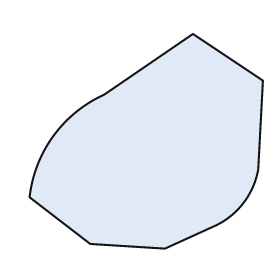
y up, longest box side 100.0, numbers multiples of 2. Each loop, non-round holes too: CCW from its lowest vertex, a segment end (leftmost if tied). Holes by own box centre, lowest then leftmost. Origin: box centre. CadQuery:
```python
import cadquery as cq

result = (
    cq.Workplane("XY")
    .moveTo(8.0, -46.0)
    .lineTo(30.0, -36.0)
    .threePointArc((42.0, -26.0), (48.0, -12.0))
    .lineTo(50.0, 26.0)
    .lineTo(20.0, 46.0)
    .lineTo(-18.0, 20.0)
    .threePointArc((-40.0, 2.0), (-50.0, -24.0))
    .lineTo(-24.0, -44.0)
    .close()
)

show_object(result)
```